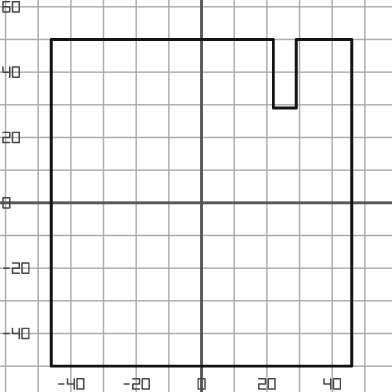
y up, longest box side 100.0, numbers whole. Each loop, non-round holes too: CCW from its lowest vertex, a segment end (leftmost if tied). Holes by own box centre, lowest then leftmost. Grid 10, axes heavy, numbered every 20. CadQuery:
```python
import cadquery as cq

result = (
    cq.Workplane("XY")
    .moveTo(-46.0, -50.0)
    .lineTo(46.0, -50.0)
    .lineTo(46.0, 50.0)
    .lineTo(29.0, 50.0)
    .lineTo(29.0, 29.0)
    .lineTo(22.0, 29.0)
    .lineTo(22.0, 50.0)
    .lineTo(-46.0, 50.0)
    .close()
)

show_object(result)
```